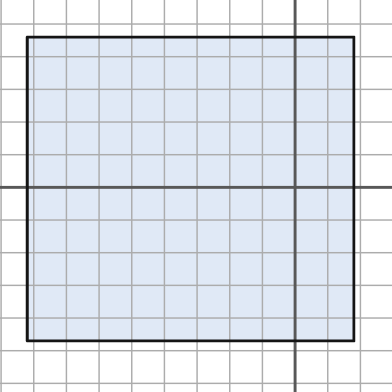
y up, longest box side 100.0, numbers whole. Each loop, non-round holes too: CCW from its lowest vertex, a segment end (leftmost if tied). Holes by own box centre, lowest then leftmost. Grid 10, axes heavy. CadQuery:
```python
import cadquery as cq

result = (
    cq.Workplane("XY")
    .moveTo(-82.0, -47.0)
    .lineTo(18.0, -47.0)
    .lineTo(18.0, 46.0)
    .lineTo(-82.0, 46.0)
    .close()
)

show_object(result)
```